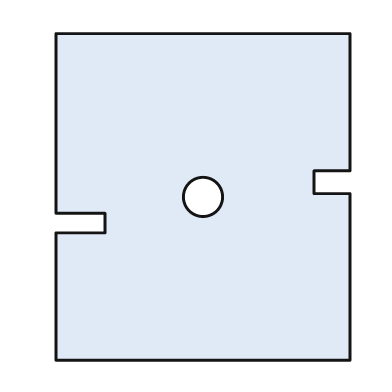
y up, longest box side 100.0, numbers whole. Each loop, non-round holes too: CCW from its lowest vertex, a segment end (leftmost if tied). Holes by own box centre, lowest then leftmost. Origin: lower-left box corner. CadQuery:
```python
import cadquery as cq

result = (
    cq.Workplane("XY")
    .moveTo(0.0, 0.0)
    .lineTo(90.0, 0.0)
    .lineTo(90.0, 51.0)
    .lineTo(79.0, 51.0)
    .lineTo(79.0, 58.0)
    .lineTo(90.0, 58.0)
    .lineTo(90.0, 100.0)
    .lineTo(0.0, 100.0)
    .lineTo(0.0, 45.0)
    .lineTo(15.0, 45.0)
    .lineTo(15.0, 39.0)
    .lineTo(0.0, 39.0)
    .close()
    .moveTo(45.0, 50.0)
    .circle(6.0)
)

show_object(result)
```